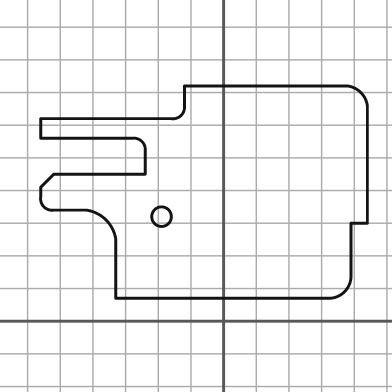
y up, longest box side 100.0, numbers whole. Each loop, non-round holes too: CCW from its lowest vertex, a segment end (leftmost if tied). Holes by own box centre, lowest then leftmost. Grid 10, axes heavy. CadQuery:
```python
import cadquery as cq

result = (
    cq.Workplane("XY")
    .moveTo(-33.0, 7.0)
    .lineTo(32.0, 7.0)
    .threePointArc((37.0, 9.0), (39.0, 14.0))
    .lineTo(39.0, 30.0)
    .lineTo(44.0, 30.0)
    .lineTo(44.0, 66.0)
    .threePointArc((42.0, 70.0), (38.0, 72.0))
    .lineTo(-12.0, 72.0)
    .lineTo(-12.0, 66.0)
    .threePointArc((-13.0, 63.0), (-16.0, 62.0))
    .lineTo(-56.0, 62.0)
    .lineTo(-56.0, 56.0)
    .lineTo(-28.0, 56.0)
    .threePointArc((-25.0, 55.0), (-24.0, 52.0))
    .lineTo(-24.0, 45.0)
    .lineTo(-52.0, 45.0)
    .lineTo(-56.0, 41.0)
    .lineTo(-56.0, 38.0)
    .threePointArc((-55.0, 35.0), (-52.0, 34.0))
    .lineTo(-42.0, 34.0)
    .threePointArc((-36.0, 31.0), (-33.0, 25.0))
    .close()
    .moveTo(-19.0, 32.0)
    .circle(3.0)
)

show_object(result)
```